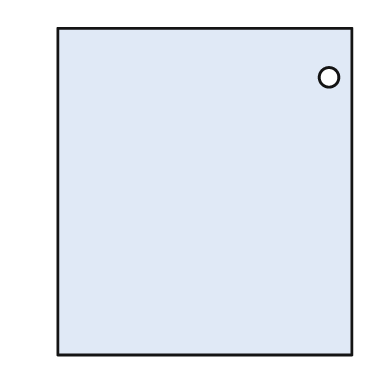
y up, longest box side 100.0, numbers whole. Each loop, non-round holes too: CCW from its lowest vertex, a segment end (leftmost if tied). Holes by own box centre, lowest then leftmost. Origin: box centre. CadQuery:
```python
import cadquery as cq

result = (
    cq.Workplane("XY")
    .moveTo(-45.0, -50.0)
    .lineTo(45.0, -50.0)
    .lineTo(45.0, 50.0)
    .lineTo(-45.0, 50.0)
    .close()
    .moveTo(38.0, 35.0)
    .circle(3.0)
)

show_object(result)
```